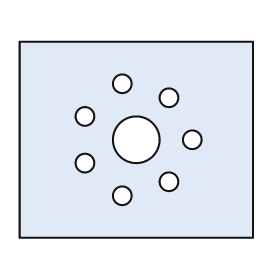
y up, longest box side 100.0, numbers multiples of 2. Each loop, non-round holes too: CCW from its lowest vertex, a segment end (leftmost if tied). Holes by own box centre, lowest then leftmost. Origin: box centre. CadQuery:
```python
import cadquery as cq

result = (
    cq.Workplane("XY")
    .moveTo(-50.0, -42.0)
    .lineTo(50.0, -42.0)
    .lineTo(50.0, 42.0)
    .lineTo(-50.0, 42.0)
    .close()
    .moveTo(-6.0, -24.0)
    .circle(4.0)
    .moveTo(14.0, -18.0)
    .circle(4.0)
    .moveTo(-22.0, -10.0)
    .circle(4.0)
    .moveTo(0.0, 0.0)
    .circle(10.0)
    .moveTo(24.0, 0.0)
    .circle(4.0)
    .moveTo(-22.0, 10.0)
    .circle(4.0)
    .moveTo(14.0, 18.0)
    .circle(4.0)
    .moveTo(-6.0, 24.0)
    .circle(4.0)
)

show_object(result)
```